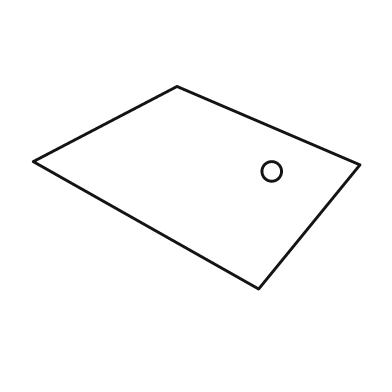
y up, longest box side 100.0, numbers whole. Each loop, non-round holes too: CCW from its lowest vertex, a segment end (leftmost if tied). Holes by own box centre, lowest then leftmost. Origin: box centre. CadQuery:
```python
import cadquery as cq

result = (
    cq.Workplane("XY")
    .moveTo(19.0, -31.0)
    .lineTo(50.0, 7.0)
    .lineTo(-6.0, 31.0)
    .lineTo(-50.0, 8.0)
    .close()
    .moveTo(23.0, 5.0)
    .circle(3.0)
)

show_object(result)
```